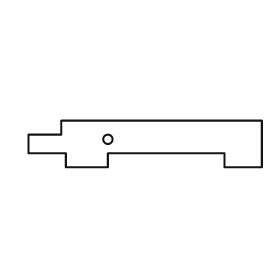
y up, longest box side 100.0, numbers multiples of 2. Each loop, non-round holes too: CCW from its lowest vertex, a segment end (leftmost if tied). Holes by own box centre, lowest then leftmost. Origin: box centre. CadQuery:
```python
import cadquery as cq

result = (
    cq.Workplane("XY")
    .moveTo(-34.0, -10.0)
    .lineTo(-16.0, -10.0)
    .lineTo(-16.0, -4.0)
    .lineTo(34.0, -4.0)
    .lineTo(34.0, -10.0)
    .lineTo(50.0, -10.0)
    .lineTo(50.0, 10.0)
    .lineTo(-36.0, 10.0)
    .lineTo(-36.0, 4.0)
    .lineTo(-50.0, 4.0)
    .lineTo(-50.0, -4.0)
    .lineTo(-34.0, -4.0)
    .close()
    .moveTo(-16.0, 2.0)
    .circle(2.0)
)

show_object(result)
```